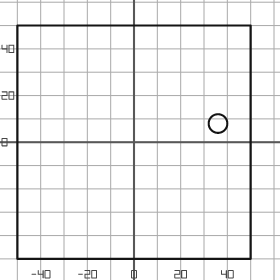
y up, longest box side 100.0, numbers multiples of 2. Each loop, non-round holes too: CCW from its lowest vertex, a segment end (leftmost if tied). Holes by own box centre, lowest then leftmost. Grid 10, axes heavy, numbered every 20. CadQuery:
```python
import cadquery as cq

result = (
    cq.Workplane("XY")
    .moveTo(-50.0, -50.0)
    .lineTo(50.0, -50.0)
    .lineTo(50.0, 50.0)
    .lineTo(-50.0, 50.0)
    .close()
    .moveTo(36.0, 8.0)
    .circle(4.0)
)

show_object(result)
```